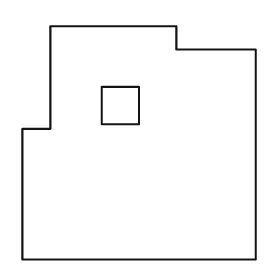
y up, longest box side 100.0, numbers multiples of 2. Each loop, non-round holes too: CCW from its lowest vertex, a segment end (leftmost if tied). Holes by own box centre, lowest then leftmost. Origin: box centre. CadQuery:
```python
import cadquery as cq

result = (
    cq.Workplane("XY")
    .moveTo(-50.0, -50.0)
    .lineTo(50.0, -50.0)
    .lineTo(50.0, 40.0)
    .lineTo(16.0, 40.0)
    .lineTo(16.0, 50.0)
    .lineTo(-38.0, 50.0)
    .lineTo(-38.0, 6.0)
    .lineTo(-50.0, 6.0)
    .close()
    .moveTo(-16.0, 8.0)
    .lineTo(0.0, 8.0)
    .lineTo(0.0, 24.0)
    .lineTo(-16.0, 24.0)
    .close()
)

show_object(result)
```